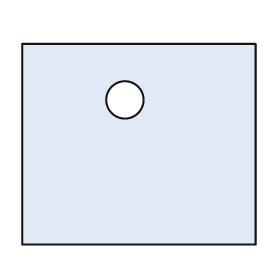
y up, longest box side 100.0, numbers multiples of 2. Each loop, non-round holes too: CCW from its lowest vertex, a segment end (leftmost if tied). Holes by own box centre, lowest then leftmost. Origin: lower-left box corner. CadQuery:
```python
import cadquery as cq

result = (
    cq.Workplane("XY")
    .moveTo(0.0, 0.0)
    .lineTo(100.0, 0.0)
    .lineTo(100.0, 86.0)
    .lineTo(0.0, 86.0)
    .close()
    .moveTo(44.0, 62.0)
    .circle(8.0)
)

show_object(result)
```